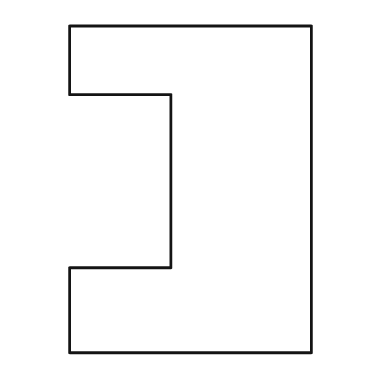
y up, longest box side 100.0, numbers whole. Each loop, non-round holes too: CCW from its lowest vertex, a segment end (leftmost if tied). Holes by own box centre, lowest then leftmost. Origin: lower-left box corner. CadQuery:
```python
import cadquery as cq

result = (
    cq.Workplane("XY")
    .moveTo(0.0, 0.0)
    .lineTo(74.0, 0.0)
    .lineTo(74.0, 100.0)
    .lineTo(0.0, 100.0)
    .lineTo(0.0, 79.0)
    .lineTo(31.0, 79.0)
    .lineTo(31.0, 26.0)
    .lineTo(0.0, 26.0)
    .close()
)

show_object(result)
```